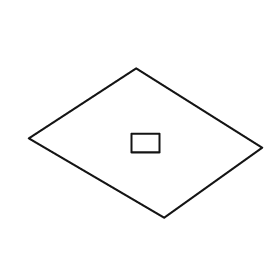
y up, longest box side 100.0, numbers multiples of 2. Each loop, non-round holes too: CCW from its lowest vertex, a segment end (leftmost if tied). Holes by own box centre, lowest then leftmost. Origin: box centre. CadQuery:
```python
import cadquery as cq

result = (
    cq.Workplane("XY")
    .moveTo(8.0, -32.0)
    .lineTo(50.0, -2.0)
    .lineTo(-4.0, 32.0)
    .lineTo(-50.0, 2.0)
    .close()
    .moveTo(-6.0, -4.0)
    .lineTo(6.0, -4.0)
    .lineTo(6.0, 4.0)
    .lineTo(-6.0, 4.0)
    .close()
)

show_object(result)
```